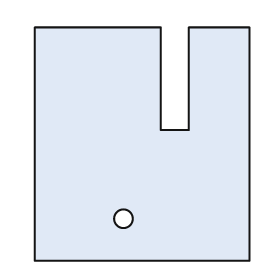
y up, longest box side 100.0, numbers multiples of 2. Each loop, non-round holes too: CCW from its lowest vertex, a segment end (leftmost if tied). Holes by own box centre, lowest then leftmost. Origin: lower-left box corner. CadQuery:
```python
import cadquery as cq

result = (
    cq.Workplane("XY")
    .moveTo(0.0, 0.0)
    .lineTo(92.0, 0.0)
    .lineTo(92.0, 100.0)
    .lineTo(66.0, 100.0)
    .lineTo(66.0, 56.0)
    .lineTo(54.0, 56.0)
    .lineTo(54.0, 100.0)
    .lineTo(0.0, 100.0)
    .close()
    .moveTo(38.0, 18.0)
    .circle(4.0)
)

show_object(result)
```